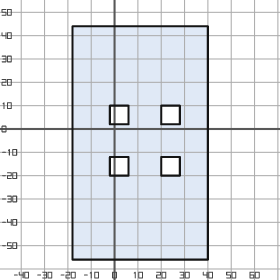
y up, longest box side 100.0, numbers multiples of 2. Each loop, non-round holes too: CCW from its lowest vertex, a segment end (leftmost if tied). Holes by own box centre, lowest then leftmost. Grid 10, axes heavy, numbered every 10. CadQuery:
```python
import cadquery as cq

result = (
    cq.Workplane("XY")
    .moveTo(-18.0, -56.0)
    .lineTo(40.0, -56.0)
    .lineTo(40.0, 44.0)
    .lineTo(-18.0, 44.0)
    .close()
    .moveTo(-2.0, -20.0)
    .lineTo(6.0, -20.0)
    .lineTo(6.0, -12.0)
    .lineTo(-2.0, -12.0)
    .close()
    .moveTo(20.0, -20.0)
    .lineTo(28.0, -20.0)
    .lineTo(28.0, -12.0)
    .lineTo(20.0, -12.0)
    .close()
    .moveTo(-2.0, 2.0)
    .lineTo(6.0, 2.0)
    .lineTo(6.0, 10.0)
    .lineTo(-2.0, 10.0)
    .close()
    .moveTo(20.0, 2.0)
    .lineTo(28.0, 2.0)
    .lineTo(28.0, 10.0)
    .lineTo(20.0, 10.0)
    .close()
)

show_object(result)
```